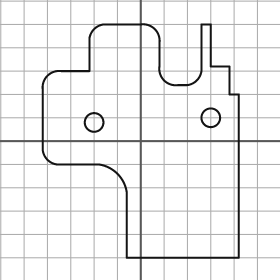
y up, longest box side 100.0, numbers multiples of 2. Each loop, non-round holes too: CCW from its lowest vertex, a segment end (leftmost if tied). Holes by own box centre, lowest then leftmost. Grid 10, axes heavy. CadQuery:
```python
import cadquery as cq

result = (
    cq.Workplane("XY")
    .moveTo(-6.0, -50.0)
    .lineTo(42.0, -50.0)
    .lineTo(42.0, 20.0)
    .lineTo(38.0, 20.0)
    .lineTo(38.0, 32.0)
    .lineTo(30.0, 32.0)
    .lineTo(30.0, 50.0)
    .lineTo(26.0, 50.0)
    .lineTo(26.0, 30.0)
    .threePointArc((24.0, 26.0), (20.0, 24.0))
    .lineTo(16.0, 24.0)
    .threePointArc((10.0, 26.0), (8.0, 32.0))
    .lineTo(8.0, 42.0)
    .threePointArc((6.0, 48.0), (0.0, 50.0))
    .lineTo(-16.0, 50.0)
    .threePointArc((-20.0, 48.0), (-22.0, 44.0))
    .lineTo(-22.0, 30.0)
    .lineTo(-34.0, 30.0)
    .threePointArc((-40.0, 28.0), (-42.0, 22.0))
    .lineTo(-42.0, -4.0)
    .threePointArc((-40.0, -8.0), (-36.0, -10.0))
    .lineTo(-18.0, -10.0)
    .threePointArc((-10.0, -14.0), (-6.0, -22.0))
    .close()
    .moveTo(-20.0, 8.0)
    .circle(4.0)
    .moveTo(30.0, 10.0)
    .circle(4.0)
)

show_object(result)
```